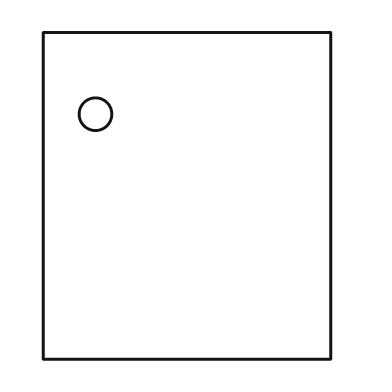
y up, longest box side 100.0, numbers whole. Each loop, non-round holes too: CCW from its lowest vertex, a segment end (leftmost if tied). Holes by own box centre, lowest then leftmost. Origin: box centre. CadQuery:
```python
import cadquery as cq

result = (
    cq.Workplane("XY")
    .moveTo(-44.0, -50.0)
    .lineTo(44.0, -50.0)
    .lineTo(44.0, 50.0)
    .lineTo(-44.0, 50.0)
    .close()
    .moveTo(-28.0, 25.0)
    .circle(5.0)
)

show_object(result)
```